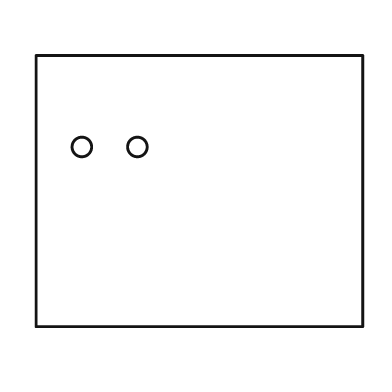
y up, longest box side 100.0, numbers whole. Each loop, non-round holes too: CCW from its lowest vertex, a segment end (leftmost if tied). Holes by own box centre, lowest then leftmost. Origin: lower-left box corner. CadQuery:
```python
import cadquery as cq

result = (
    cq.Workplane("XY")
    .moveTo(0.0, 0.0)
    .lineTo(100.0, 0.0)
    .lineTo(100.0, 83.0)
    .lineTo(0.0, 83.0)
    .close()
    .moveTo(14.0, 55.0)
    .circle(3.0)
    .moveTo(31.0, 55.0)
    .circle(3.0)
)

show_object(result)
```